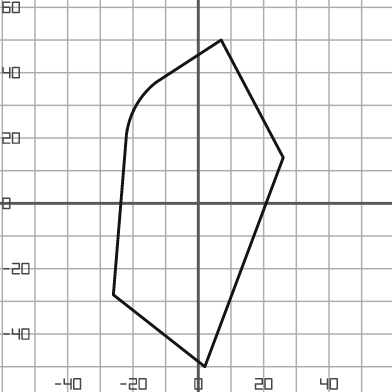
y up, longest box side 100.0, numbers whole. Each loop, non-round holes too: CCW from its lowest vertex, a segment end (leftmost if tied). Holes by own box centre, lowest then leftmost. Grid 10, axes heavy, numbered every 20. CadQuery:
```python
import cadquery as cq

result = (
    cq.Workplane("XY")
    .moveTo(2.0, -50.0)
    .lineTo(26.0, 14.0)
    .lineTo(7.0, 50.0)
    .lineTo(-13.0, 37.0)
    .threePointArc((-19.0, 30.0), (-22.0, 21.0))
    .lineTo(-26.0, -28.0)
    .close()
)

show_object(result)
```